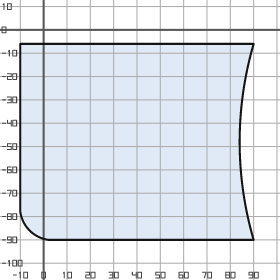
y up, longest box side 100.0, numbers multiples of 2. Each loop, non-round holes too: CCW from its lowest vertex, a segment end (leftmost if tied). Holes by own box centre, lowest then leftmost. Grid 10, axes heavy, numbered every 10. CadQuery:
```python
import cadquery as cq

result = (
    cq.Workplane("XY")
    .moveTo(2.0, -90.0)
    .lineTo(90.0, -90.0)
    .threePointArc((84.0, -48.0), (90.0, -6.0))
    .lineTo(-10.0, -6.0)
    .lineTo(-10.0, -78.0)
    .threePointArc((-6.0, -86.0), (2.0, -90.0))
    .close()
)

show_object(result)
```